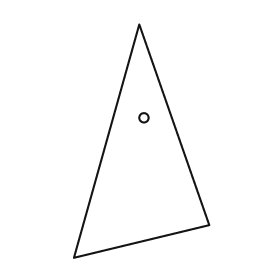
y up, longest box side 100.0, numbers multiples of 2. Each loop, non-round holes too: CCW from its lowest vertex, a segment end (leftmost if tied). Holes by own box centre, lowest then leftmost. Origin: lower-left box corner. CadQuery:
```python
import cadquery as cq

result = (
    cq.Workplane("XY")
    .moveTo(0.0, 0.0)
    .lineTo(58.0, 14.0)
    .lineTo(28.0, 100.0)
    .close()
    .moveTo(30.0, 60.0)
    .circle(2.0)
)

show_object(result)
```